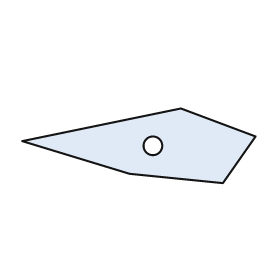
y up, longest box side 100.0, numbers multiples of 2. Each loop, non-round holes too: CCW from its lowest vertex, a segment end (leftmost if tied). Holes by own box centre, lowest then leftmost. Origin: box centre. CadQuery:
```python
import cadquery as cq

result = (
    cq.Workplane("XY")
    .moveTo(36.0, -16.0)
    .lineTo(50.0, 4.0)
    .lineTo(18.0, 16.0)
    .lineTo(-50.0, 2.0)
    .lineTo(-4.0, -12.0)
    .close()
    .moveTo(6.0, 0.0)
    .circle(4.0)
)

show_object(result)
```